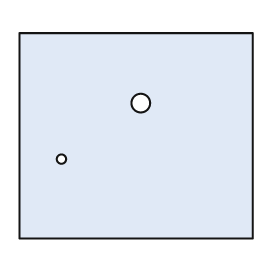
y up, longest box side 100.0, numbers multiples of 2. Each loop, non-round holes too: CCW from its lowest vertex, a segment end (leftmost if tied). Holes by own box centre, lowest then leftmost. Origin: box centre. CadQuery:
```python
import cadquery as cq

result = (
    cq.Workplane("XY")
    .moveTo(-50.0, -44.0)
    .lineTo(50.0, -44.0)
    .lineTo(50.0, 44.0)
    .lineTo(-50.0, 44.0)
    .close()
    .moveTo(-32.0, -10.0)
    .circle(2.0)
    .moveTo(2.0, 14.0)
    .circle(4.0)
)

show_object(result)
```